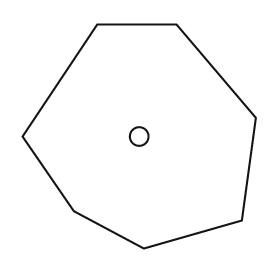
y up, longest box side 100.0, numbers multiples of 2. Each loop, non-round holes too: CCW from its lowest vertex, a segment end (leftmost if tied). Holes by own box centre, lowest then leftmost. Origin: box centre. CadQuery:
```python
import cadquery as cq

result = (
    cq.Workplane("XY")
    .moveTo(2.0, -48.0)
    .lineTo(44.0, -36.0)
    .lineTo(50.0, 8.0)
    .lineTo(16.0, 48.0)
    .lineTo(-18.0, 48.0)
    .lineTo(-50.0, 0.0)
    .lineTo(-28.0, -32.0)
    .close()
    .moveTo(0.0, 0.0)
    .circle(4.0)
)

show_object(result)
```